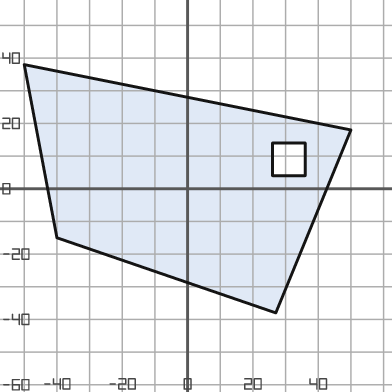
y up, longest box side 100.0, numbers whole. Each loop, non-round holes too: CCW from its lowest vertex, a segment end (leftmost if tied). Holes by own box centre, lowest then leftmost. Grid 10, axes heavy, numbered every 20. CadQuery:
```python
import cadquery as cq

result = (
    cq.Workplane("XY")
    .moveTo(27.0, -38.0)
    .lineTo(50.0, 18.0)
    .lineTo(-50.0, 38.0)
    .lineTo(-40.0, -15.0)
    .close()
    .moveTo(26.0, 4.0)
    .lineTo(36.0, 4.0)
    .lineTo(36.0, 14.0)
    .lineTo(26.0, 14.0)
    .close()
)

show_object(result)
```